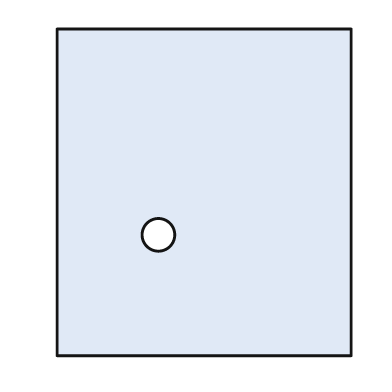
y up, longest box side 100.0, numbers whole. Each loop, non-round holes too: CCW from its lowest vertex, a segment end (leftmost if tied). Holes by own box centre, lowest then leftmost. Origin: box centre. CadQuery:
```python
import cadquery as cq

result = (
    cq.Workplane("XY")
    .moveTo(-45.0, -50.0)
    .lineTo(45.0, -50.0)
    .lineTo(45.0, 50.0)
    .lineTo(-45.0, 50.0)
    .close()
    .moveTo(-14.0, -13.0)
    .circle(5.0)
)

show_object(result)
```